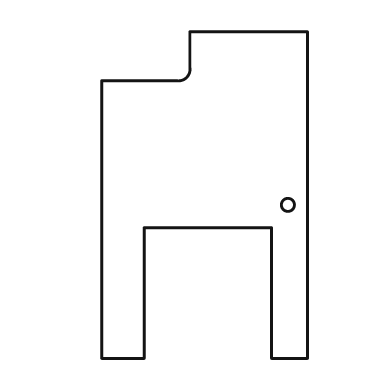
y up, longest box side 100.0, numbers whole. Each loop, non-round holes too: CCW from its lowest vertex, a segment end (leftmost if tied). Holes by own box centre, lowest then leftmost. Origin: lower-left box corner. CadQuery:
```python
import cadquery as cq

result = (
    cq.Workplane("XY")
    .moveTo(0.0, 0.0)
    .lineTo(13.0, 0.0)
    .lineTo(13.0, 40.0)
    .lineTo(52.0, 40.0)
    .lineTo(52.0, 0.0)
    .lineTo(63.0, 0.0)
    .lineTo(63.0, 100.0)
    .lineTo(27.0, 100.0)
    .lineTo(27.0, 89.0)
    .threePointArc((26.0, 86.0), (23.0, 85.0))
    .lineTo(0.0, 85.0)
    .close()
    .moveTo(57.0, 47.0)
    .circle(2.0)
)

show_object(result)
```